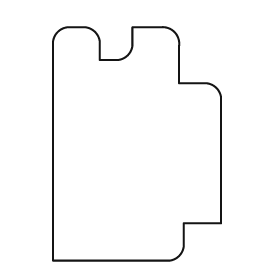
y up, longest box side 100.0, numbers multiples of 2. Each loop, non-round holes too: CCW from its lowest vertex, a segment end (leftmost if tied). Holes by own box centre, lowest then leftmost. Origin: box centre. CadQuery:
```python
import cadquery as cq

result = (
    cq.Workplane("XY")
    .moveTo(-36.0, -50.0)
    .lineTo(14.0, -50.0)
    .threePointArc((18.0, -48.0), (20.0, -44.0))
    .lineTo(20.0, -34.0)
    .lineTo(36.0, -34.0)
    .lineTo(36.0, 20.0)
    .threePointArc((34.0, 24.0), (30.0, 26.0))
    .lineTo(18.0, 26.0)
    .lineTo(18.0, 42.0)
    .threePointArc((16.0, 48.0), (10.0, 50.0))
    .lineTo(-2.0, 50.0)
    .lineTo(-2.0, 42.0)
    .threePointArc((-4.0, 38.0), (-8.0, 36.0))
    .lineTo(-16.0, 36.0)
    .lineTo(-16.0, 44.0)
    .threePointArc((-18.0, 48.0), (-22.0, 50.0))
    .lineTo(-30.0, 50.0)
    .threePointArc((-34.0, 48.0), (-36.0, 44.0))
    .close()
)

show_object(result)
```